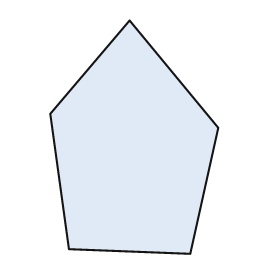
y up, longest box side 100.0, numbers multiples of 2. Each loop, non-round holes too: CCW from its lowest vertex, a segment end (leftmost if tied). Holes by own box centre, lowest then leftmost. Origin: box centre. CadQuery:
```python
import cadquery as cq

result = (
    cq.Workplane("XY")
    .moveTo(24.0, -50.0)
    .lineTo(36.0, 4.0)
    .lineTo(-2.0, 50.0)
    .lineTo(-36.0, 10.0)
    .lineTo(-28.0, -48.0)
    .close()
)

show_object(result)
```